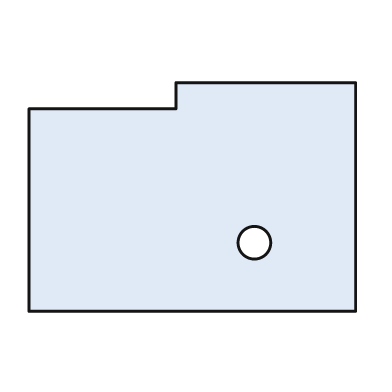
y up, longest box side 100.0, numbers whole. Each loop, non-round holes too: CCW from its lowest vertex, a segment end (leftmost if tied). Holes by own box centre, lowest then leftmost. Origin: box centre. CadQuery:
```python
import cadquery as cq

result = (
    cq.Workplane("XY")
    .moveTo(-50.0, -35.0)
    .lineTo(50.0, -35.0)
    .lineTo(50.0, 35.0)
    .lineTo(-5.0, 35.0)
    .lineTo(-5.0, 27.0)
    .lineTo(-50.0, 27.0)
    .close()
    .moveTo(19.0, -14.0)
    .circle(5.0)
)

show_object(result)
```